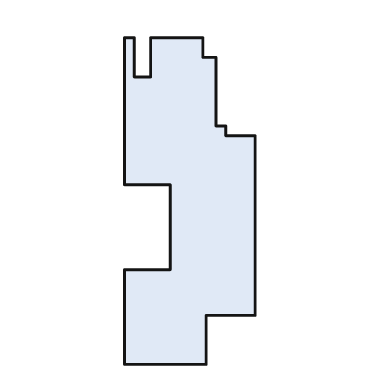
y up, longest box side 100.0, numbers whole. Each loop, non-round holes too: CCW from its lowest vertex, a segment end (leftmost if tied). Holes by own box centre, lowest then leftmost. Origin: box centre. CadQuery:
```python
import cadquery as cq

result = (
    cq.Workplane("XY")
    .moveTo(-20.0, -50.0)
    .lineTo(5.0, -50.0)
    .lineTo(5.0, -35.0)
    .lineTo(20.0, -35.0)
    .lineTo(20.0, 20.0)
    .lineTo(11.0, 20.0)
    .lineTo(11.0, 23.0)
    .lineTo(8.0, 23.0)
    .lineTo(8.0, 44.0)
    .lineTo(4.0, 44.0)
    .lineTo(4.0, 50.0)
    .lineTo(-12.0, 50.0)
    .lineTo(-12.0, 38.0)
    .lineTo(-17.0, 38.0)
    .lineTo(-17.0, 50.0)
    .lineTo(-20.0, 50.0)
    .lineTo(-20.0, 5.0)
    .lineTo(-6.0, 5.0)
    .lineTo(-6.0, -21.0)
    .lineTo(-20.0, -21.0)
    .close()
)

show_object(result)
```